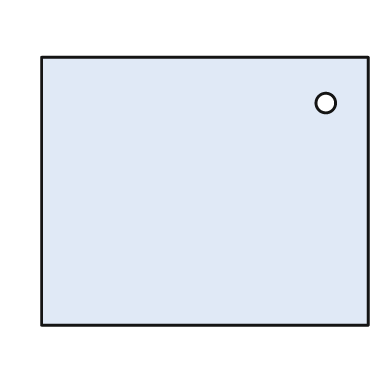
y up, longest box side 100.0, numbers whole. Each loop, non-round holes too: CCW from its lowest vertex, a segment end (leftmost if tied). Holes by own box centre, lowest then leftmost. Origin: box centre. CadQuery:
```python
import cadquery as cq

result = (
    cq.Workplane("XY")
    .moveTo(-50.0, -41.0)
    .lineTo(50.0, -41.0)
    .lineTo(50.0, 41.0)
    .lineTo(-50.0, 41.0)
    .close()
    .moveTo(37.0, 27.0)
    .circle(3.0)
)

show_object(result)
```